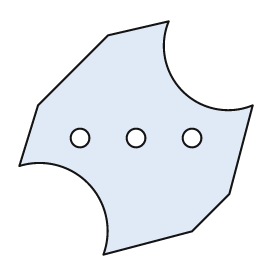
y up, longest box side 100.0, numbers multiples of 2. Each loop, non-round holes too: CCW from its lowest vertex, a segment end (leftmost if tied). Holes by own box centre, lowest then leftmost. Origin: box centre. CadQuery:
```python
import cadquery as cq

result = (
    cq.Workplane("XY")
    .moveTo(-14.0, -50.0)
    .lineTo(24.0, -40.0)
    .lineTo(40.0, -24.0)
    .lineTo(50.0, 14.0)
    .threePointArc((20.0, 20.0), (14.0, 50.0))
    .lineTo(-12.0, 44.0)
    .lineTo(-42.0, 14.0)
    .lineTo(-50.0, -12.0)
    .threePointArc((-20.0, -20.0), (-14.0, -50.0))
    .close()
    .moveTo(-24.0, 0.0)
    .circle(4.0)
    .moveTo(0.0, 0.0)
    .circle(4.0)
    .moveTo(24.0, 0.0)
    .circle(4.0)
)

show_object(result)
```